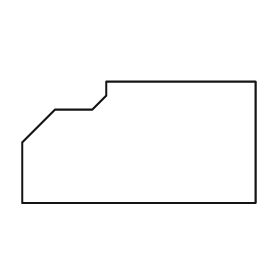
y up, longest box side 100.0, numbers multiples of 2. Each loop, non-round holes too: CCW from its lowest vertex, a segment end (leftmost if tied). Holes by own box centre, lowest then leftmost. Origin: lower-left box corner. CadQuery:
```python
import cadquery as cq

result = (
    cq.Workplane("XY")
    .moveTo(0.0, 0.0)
    .lineTo(100.0, 0.0)
    .lineTo(100.0, 52.0)
    .lineTo(36.0, 52.0)
    .lineTo(36.0, 46.0)
    .lineTo(30.0, 40.0)
    .lineTo(14.0, 40.0)
    .lineTo(0.0, 26.0)
    .close()
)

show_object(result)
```